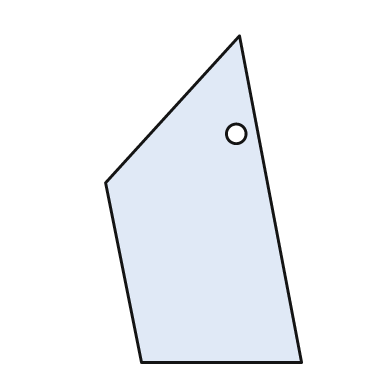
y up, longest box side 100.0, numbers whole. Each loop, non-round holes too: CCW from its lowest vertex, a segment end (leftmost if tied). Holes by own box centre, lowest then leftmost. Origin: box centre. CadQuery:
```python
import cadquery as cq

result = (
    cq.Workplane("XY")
    .moveTo(-19.0, -50.0)
    .lineTo(30.0, -50.0)
    .lineTo(11.0, 50.0)
    .lineTo(-30.0, 5.0)
    .close()
    .moveTo(10.0, 20.0)
    .circle(3.0)
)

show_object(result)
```